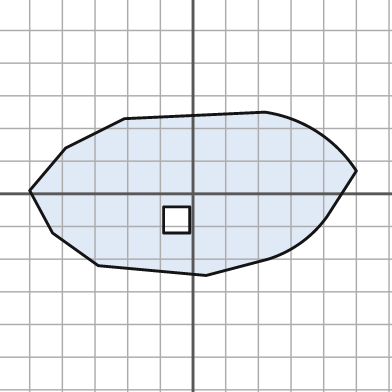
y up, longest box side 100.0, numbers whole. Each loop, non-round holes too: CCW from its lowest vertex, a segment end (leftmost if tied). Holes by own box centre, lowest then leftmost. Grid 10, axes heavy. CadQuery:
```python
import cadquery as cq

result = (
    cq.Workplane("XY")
    .moveTo(4.0, -25.0)
    .lineTo(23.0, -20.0)
    .threePointArc((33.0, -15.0), (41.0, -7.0))
    .lineTo(50.0, 7.0)
    .threePointArc((38.0, 19.0), (22.0, 25.0))
    .lineTo(-21.0, 23.0)
    .lineTo(-39.0, 14.0)
    .lineTo(-50.0, 1.0)
    .lineTo(-43.0, -12.0)
    .lineTo(-29.0, -22.0)
    .close()
    .moveTo(-9.0, -12.0)
    .lineTo(-1.0, -12.0)
    .lineTo(-1.0, -4.0)
    .lineTo(-9.0, -4.0)
    .close()
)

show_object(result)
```